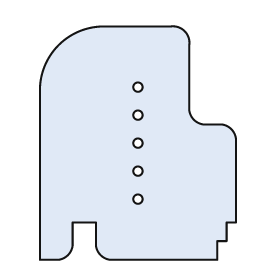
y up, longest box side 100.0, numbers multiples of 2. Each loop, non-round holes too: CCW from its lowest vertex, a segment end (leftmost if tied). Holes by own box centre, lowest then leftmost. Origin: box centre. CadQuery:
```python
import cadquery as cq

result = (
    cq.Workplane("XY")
    .moveTo(-42.0, -50.0)
    .lineTo(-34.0, -50.0)
    .threePointArc((-30.0, -48.0), (-28.0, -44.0))
    .lineTo(-28.0, -34.0)
    .lineTo(-18.0, -34.0)
    .lineTo(-18.0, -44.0)
    .threePointArc((-16.0, -48.0), (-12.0, -50.0))
    .lineTo(34.0, -50.0)
    .lineTo(34.0, -42.0)
    .lineTo(38.0, -42.0)
    .lineTo(38.0, -34.0)
    .lineTo(42.0, -34.0)
    .lineTo(42.0, 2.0)
    .threePointArc((40.0, 6.0), (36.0, 8.0))
    .lineTo(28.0, 8.0)
    .threePointArc((24.0, 10.0), (22.0, 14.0))
    .lineTo(22.0, 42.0)
    .threePointArc((20.0, 48.0), (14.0, 50.0))
    .lineTo(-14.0, 50.0)
    .threePointArc((-34.0, 42.0), (-42.0, 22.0))
    .close()
    .moveTo(0.0, -24.0)
    .circle(2.0)
    .moveTo(0.0, -12.0)
    .circle(2.0)
    .moveTo(0.0, 0.0)
    .circle(2.0)
    .moveTo(0.0, 12.0)
    .circle(2.0)
    .moveTo(0.0, 24.0)
    .circle(2.0)
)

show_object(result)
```